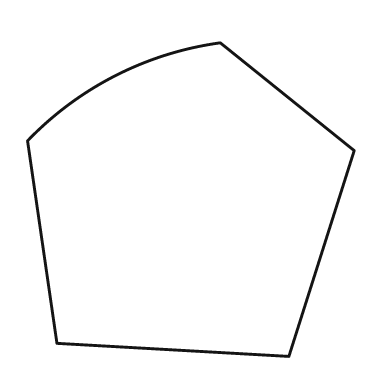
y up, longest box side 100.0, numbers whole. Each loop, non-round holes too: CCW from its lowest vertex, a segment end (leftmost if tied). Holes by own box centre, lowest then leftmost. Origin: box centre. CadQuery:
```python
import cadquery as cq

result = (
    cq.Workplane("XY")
    .moveTo(30.0, -48.0)
    .lineTo(50.0, 15.0)
    .lineTo(9.0, 48.0)
    .threePointArc((-23.0, 38.0), (-50.0, 18.0))
    .lineTo(-41.0, -44.0)
    .close()
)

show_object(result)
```